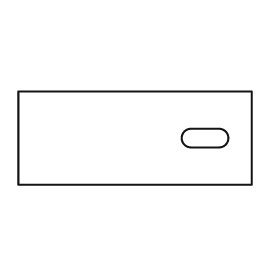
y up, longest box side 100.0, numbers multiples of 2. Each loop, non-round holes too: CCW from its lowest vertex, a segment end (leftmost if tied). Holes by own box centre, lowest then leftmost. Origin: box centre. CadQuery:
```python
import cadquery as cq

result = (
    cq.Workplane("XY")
    .moveTo(-50.0, -20.0)
    .lineTo(50.0, -20.0)
    .lineTo(50.0, 20.0)
    .lineTo(-50.0, 20.0)
    .close()
    .moveTo(24.0, -4.0)
    .lineTo(36.0, -4.0)
    .threePointArc((40.0, 0.0), (36.0, 4.0))
    .lineTo(24.0, 4.0)
    .threePointArc((20.0, 0.0), (24.0, -4.0))
    .close()
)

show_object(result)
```